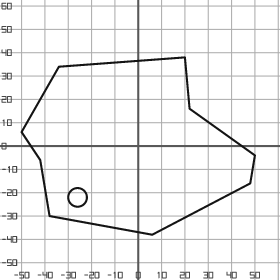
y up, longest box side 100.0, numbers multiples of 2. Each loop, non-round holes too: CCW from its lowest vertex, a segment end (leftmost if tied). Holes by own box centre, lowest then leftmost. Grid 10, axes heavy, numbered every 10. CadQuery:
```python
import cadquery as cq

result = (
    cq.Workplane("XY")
    .moveTo(6.0, -38.0)
    .lineTo(48.0, -16.0)
    .lineTo(50.0, -4.0)
    .lineTo(22.0, 16.0)
    .lineTo(20.0, 38.0)
    .lineTo(-34.0, 34.0)
    .lineTo(-50.0, 6.0)
    .lineTo(-42.0, -6.0)
    .lineTo(-38.0, -30.0)
    .close()
    .moveTo(-26.0, -22.0)
    .circle(4.0)
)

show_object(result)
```